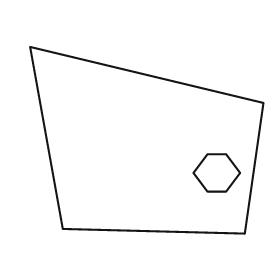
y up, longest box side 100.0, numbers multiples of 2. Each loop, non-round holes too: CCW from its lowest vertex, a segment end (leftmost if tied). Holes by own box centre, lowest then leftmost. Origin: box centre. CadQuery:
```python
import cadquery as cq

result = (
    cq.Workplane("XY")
    .moveTo(42.0, -40.0)
    .lineTo(50.0, 16.0)
    .lineTo(-50.0, 40.0)
    .lineTo(-36.0, -38.0)
    .close()
    .moveTo(26.0, -22.0)
    .lineTo(34.0, -22.0)
    .lineTo(40.0, -14.0)
    .lineTo(34.0, -6.0)
    .lineTo(26.0, -6.0)
    .lineTo(20.0, -14.0)
    .close()
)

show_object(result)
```